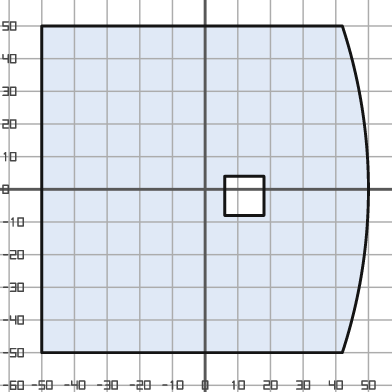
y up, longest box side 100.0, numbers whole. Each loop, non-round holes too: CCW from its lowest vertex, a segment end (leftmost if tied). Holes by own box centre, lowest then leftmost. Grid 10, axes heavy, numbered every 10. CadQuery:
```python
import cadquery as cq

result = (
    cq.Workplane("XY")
    .moveTo(-50.0, -50.0)
    .lineTo(42.0, -50.0)
    .threePointArc((50.0, 0.0), (42.0, 50.0))
    .lineTo(-50.0, 50.0)
    .close()
    .moveTo(6.0, -8.0)
    .lineTo(18.0, -8.0)
    .lineTo(18.0, 4.0)
    .lineTo(6.0, 4.0)
    .close()
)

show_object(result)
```